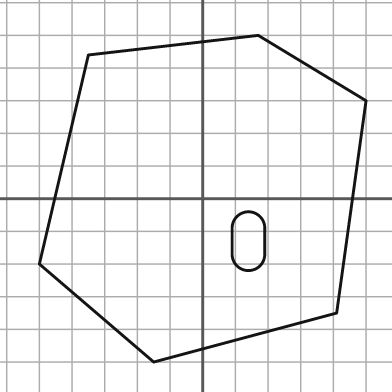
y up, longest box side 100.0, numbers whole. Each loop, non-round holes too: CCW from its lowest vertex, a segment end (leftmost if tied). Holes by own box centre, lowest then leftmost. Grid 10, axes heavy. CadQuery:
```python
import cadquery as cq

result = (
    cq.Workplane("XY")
    .moveTo(-15.0, -50.0)
    .lineTo(41.0, -35.0)
    .lineTo(50.0, 30.0)
    .lineTo(17.0, 50.0)
    .lineTo(-35.0, 44.0)
    .lineTo(-50.0, -20.0)
    .close()
    .moveTo(9.0, -17.0)
    .threePointArc((14.0, -22.0), (19.0, -17.0))
    .lineTo(19.0, -9.0)
    .threePointArc((14.0, -4.0), (9.0, -9.0))
    .close()
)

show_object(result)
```